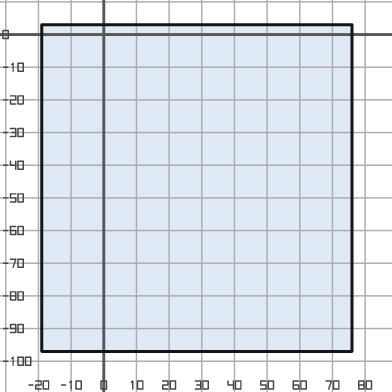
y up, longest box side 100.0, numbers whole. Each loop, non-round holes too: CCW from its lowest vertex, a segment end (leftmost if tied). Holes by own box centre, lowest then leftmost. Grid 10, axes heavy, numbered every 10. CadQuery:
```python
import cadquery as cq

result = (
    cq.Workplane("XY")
    .moveTo(-19.0, -97.0)
    .lineTo(76.0, -97.0)
    .lineTo(76.0, 3.0)
    .lineTo(-19.0, 3.0)
    .close()
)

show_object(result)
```